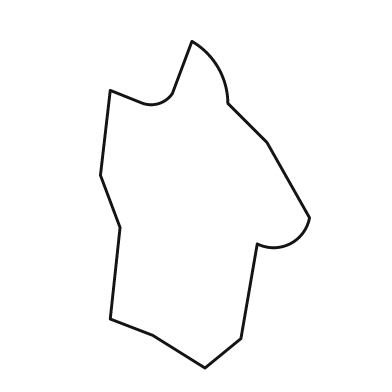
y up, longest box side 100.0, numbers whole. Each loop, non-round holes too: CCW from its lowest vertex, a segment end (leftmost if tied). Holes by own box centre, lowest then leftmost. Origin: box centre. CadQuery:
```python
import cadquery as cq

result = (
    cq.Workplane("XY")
    .moveTo(0.0, -50.0)
    .lineTo(11.0, -41.0)
    .lineTo(16.0, -12.0)
    .threePointArc((26.0, -12.0), (32.0, -4.0))
    .lineTo(19.0, 19.0)
    .lineTo(7.0, 31.0)
    .threePointArc((4.0, 42.0), (-4.0, 50.0))
    .lineTo(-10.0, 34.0)
    .threePointArc((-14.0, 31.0), (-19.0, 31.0))
    .lineTo(-29.0, 35.0)
    .lineTo(-32.0, 9.0)
    .lineTo(-26.0, -7.0)
    .lineTo(-29.0, -35.0)
    .lineTo(-16.0, -40.0)
    .close()
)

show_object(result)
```